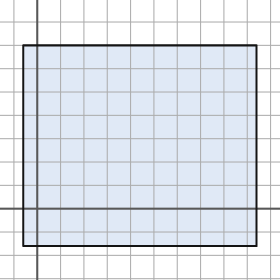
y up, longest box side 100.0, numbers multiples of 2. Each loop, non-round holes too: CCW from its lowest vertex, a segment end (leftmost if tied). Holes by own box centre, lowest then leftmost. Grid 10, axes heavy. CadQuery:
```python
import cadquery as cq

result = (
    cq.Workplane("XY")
    .moveTo(-6.0, -16.0)
    .lineTo(94.0, -16.0)
    .lineTo(94.0, 70.0)
    .lineTo(-6.0, 70.0)
    .close()
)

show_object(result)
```